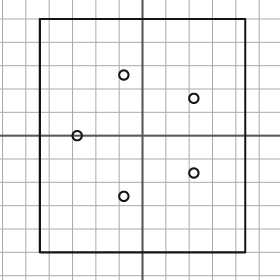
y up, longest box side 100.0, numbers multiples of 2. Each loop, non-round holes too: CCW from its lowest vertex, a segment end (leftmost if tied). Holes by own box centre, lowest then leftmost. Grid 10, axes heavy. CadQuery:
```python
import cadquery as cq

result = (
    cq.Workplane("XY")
    .moveTo(-44.0, -50.0)
    .lineTo(44.0, -50.0)
    .lineTo(44.0, 50.0)
    .lineTo(-44.0, 50.0)
    .close()
    .moveTo(-8.0, -26.0)
    .circle(2.0)
    .moveTo(22.0, -16.0)
    .circle(2.0)
    .moveTo(-28.0, 0.0)
    .circle(2.0)
    .moveTo(22.0, 16.0)
    .circle(2.0)
    .moveTo(-8.0, 26.0)
    .circle(2.0)
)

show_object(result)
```